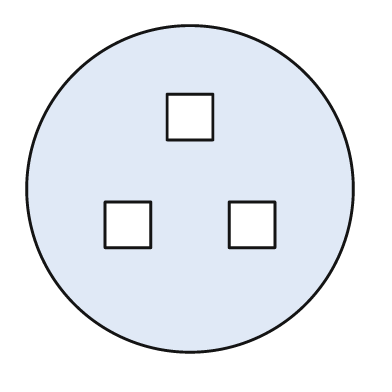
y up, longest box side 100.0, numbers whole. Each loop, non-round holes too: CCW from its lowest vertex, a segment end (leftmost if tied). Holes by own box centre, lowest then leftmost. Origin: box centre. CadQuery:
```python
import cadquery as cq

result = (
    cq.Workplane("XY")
    .moveTo(0.0, 0.0)
    .circle(50.0)
    .moveTo(-26.0, -18.0)
    .lineTo(-12.0, -18.0)
    .lineTo(-12.0, -4.0)
    .lineTo(-26.0, -4.0)
    .close()
    .moveTo(12.0, -18.0)
    .lineTo(26.0, -18.0)
    .lineTo(26.0, -4.0)
    .lineTo(12.0, -4.0)
    .close()
    .moveTo(-7.0, 15.0)
    .lineTo(7.0, 15.0)
    .lineTo(7.0, 29.0)
    .lineTo(-7.0, 29.0)
    .close()
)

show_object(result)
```